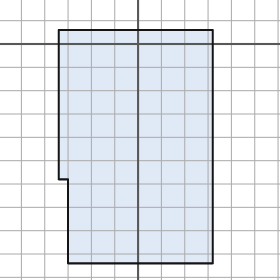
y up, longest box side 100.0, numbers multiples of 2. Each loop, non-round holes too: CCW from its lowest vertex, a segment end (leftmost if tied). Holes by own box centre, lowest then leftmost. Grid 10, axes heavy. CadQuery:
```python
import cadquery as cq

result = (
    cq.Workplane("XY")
    .moveTo(-30.0, -94.0)
    .lineTo(32.0, -94.0)
    .lineTo(32.0, 6.0)
    .lineTo(-34.0, 6.0)
    .lineTo(-34.0, -58.0)
    .lineTo(-30.0, -58.0)
    .close()
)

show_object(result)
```